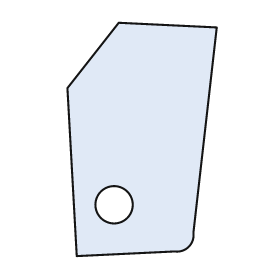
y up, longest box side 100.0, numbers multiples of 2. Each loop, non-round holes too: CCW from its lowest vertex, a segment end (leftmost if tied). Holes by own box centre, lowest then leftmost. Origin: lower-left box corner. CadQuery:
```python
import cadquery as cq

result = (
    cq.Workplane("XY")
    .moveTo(4.0, 0.0)
    .lineTo(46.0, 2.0)
    .threePointArc((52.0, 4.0), (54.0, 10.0))
    .lineTo(64.0, 98.0)
    .lineTo(22.0, 100.0)
    .lineTo(0.0, 72.0)
    .close()
    .moveTo(20.0, 22.0)
    .circle(8.0)
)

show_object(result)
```